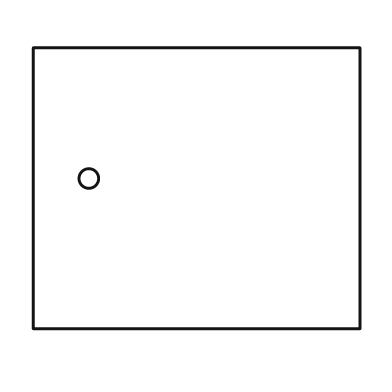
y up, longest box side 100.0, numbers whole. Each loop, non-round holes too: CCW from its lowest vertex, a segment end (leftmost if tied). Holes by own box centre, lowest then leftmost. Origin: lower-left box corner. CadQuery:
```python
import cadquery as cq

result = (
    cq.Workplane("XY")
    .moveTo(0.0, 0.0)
    .lineTo(100.0, 0.0)
    .lineTo(100.0, 86.0)
    .lineTo(0.0, 86.0)
    .close()
    .moveTo(17.0, 46.0)
    .circle(3.0)
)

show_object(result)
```